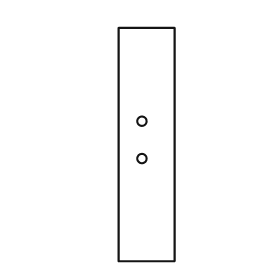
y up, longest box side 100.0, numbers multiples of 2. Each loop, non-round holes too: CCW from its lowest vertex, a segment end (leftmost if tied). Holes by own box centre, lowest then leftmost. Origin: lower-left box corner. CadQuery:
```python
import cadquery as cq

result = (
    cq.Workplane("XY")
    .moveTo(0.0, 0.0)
    .lineTo(24.0, 0.0)
    .lineTo(24.0, 100.0)
    .lineTo(0.0, 100.0)
    .close()
    .moveTo(10.0, 44.0)
    .circle(2.0)
    .moveTo(10.0, 60.0)
    .circle(2.0)
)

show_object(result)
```